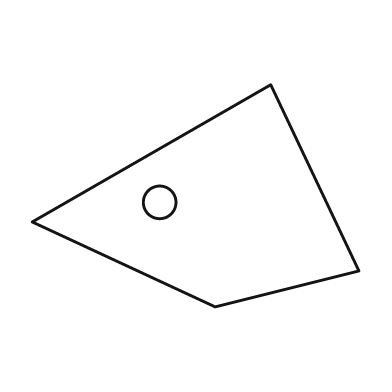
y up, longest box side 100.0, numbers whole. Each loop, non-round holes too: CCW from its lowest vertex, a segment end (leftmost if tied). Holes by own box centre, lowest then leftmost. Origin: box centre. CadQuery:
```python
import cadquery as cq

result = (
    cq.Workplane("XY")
    .moveTo(6.0, -34.0)
    .lineTo(50.0, -23.0)
    .lineTo(23.0, 34.0)
    .lineTo(-50.0, -8.0)
    .close()
    .moveTo(-11.0, -2.0)
    .circle(5.0)
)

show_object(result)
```